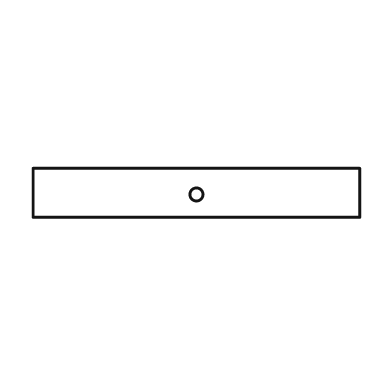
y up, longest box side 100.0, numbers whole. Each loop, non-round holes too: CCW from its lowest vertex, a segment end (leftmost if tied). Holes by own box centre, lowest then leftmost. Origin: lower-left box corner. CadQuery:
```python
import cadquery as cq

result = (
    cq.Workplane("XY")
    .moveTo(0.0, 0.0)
    .lineTo(100.0, 0.0)
    .lineTo(100.0, 15.0)
    .lineTo(0.0, 15.0)
    .close()
    .moveTo(50.0, 7.0)
    .circle(2.0)
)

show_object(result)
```